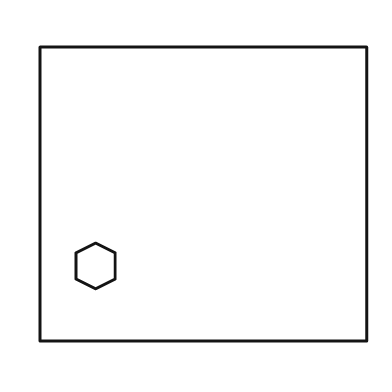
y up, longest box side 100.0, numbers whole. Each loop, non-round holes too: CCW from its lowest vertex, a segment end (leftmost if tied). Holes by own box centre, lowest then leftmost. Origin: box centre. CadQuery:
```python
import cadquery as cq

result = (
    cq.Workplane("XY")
    .moveTo(-50.0, -45.0)
    .lineTo(50.0, -45.0)
    .lineTo(50.0, 45.0)
    .lineTo(-50.0, 45.0)
    .close()
    .moveTo(-33.0, -29.0)
    .lineTo(-27.0, -26.0)
    .lineTo(-27.0, -18.0)
    .lineTo(-33.0, -15.0)
    .lineTo(-39.0, -18.0)
    .lineTo(-39.0, -26.0)
    .close()
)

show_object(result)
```